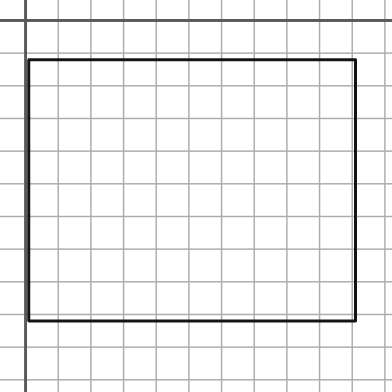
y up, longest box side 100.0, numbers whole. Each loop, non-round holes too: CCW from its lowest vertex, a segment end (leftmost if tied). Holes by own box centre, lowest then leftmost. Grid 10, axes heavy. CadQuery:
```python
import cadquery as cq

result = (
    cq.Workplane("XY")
    .moveTo(1.0, -92.0)
    .lineTo(101.0, -92.0)
    .lineTo(101.0, -12.0)
    .lineTo(1.0, -12.0)
    .close()
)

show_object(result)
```